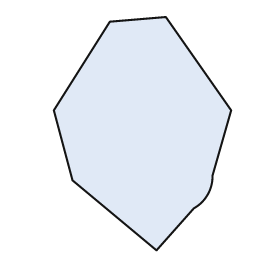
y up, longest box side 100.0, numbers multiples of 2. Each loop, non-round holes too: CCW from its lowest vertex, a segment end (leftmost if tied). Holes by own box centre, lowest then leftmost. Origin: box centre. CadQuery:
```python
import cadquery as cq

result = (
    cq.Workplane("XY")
    .moveTo(6.0, -50.0)
    .lineTo(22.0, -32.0)
    .threePointArc((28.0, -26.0), (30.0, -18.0))
    .lineTo(38.0, 10.0)
    .lineTo(10.0, 50.0)
    .lineTo(-14.0, 48.0)
    .lineTo(-38.0, 10.0)
    .lineTo(-30.0, -20.0)
    .close()
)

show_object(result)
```